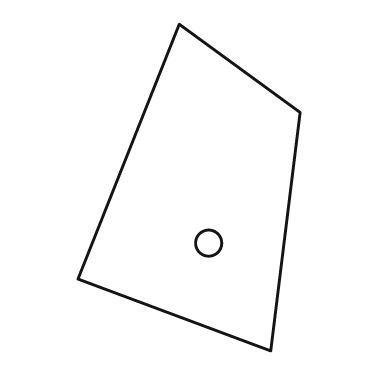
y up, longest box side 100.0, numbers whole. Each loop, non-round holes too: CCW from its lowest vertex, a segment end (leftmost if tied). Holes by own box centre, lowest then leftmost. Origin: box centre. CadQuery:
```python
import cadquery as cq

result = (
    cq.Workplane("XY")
    .moveTo(25.0, -50.0)
    .lineTo(34.0, 23.0)
    .lineTo(-3.0, 50.0)
    .lineTo(-34.0, -28.0)
    .close()
    .moveTo(6.0, -17.0)
    .circle(4.0)
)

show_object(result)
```